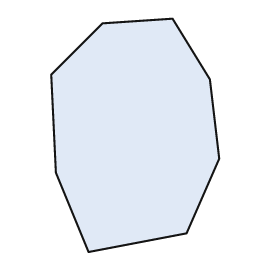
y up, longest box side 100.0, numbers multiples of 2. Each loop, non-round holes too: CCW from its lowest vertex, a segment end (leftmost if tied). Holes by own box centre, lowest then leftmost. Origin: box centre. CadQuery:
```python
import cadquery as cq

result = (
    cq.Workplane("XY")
    .moveTo(-20.0, -50.0)
    .lineTo(22.0, -42.0)
    .lineTo(36.0, -10.0)
    .lineTo(32.0, 24.0)
    .lineTo(16.0, 50.0)
    .lineTo(-14.0, 48.0)
    .lineTo(-36.0, 26.0)
    .lineTo(-34.0, -16.0)
    .close()
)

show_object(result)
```